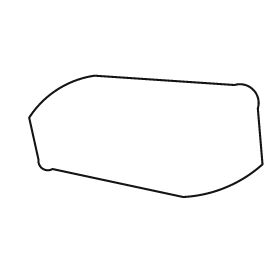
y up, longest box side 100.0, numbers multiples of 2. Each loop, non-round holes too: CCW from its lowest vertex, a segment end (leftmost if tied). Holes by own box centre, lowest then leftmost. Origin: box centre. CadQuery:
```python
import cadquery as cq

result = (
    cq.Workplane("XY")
    .moveTo(16.0, -26.0)
    .threePointArc((34.0, -22.0), (50.0, -12.0))
    .lineTo(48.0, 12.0)
    .threePointArc((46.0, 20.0), (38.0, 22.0))
    .lineTo(-22.0, 26.0)
    .threePointArc((-38.0, 20.0), (-50.0, 8.0))
    .lineTo(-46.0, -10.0)
    .threePointArc((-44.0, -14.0), (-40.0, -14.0))
    .close()
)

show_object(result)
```